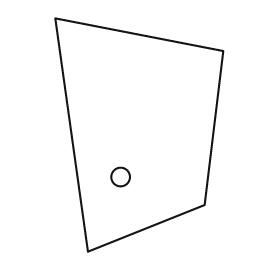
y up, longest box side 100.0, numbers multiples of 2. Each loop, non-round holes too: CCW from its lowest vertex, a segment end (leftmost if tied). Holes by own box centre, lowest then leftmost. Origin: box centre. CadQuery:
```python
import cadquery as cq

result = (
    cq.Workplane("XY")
    .moveTo(-22.0, -50.0)
    .lineTo(28.0, -30.0)
    .lineTo(36.0, 36.0)
    .lineTo(-36.0, 50.0)
    .close()
    .moveTo(-8.0, -18.0)
    .circle(4.0)
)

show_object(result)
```